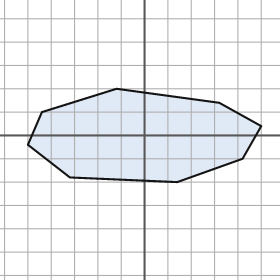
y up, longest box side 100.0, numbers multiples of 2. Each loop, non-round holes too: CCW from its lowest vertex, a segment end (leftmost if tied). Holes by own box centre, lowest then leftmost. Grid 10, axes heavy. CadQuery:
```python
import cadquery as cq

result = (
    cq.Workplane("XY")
    .moveTo(14.0, -20.0)
    .lineTo(42.0, -10.0)
    .lineTo(50.0, 4.0)
    .lineTo(32.0, 14.0)
    .lineTo(-12.0, 20.0)
    .lineTo(-44.0, 10.0)
    .lineTo(-50.0, -4.0)
    .lineTo(-32.0, -18.0)
    .close()
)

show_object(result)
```